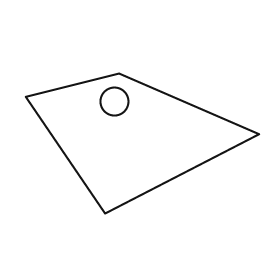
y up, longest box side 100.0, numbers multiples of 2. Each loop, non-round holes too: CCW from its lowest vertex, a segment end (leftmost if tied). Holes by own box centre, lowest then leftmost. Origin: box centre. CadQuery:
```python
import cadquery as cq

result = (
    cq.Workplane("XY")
    .moveTo(-16.0, -30.0)
    .lineTo(50.0, 4.0)
    .lineTo(-10.0, 30.0)
    .lineTo(-50.0, 20.0)
    .close()
    .moveTo(-12.0, 18.0)
    .circle(6.0)
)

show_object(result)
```